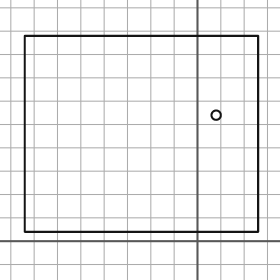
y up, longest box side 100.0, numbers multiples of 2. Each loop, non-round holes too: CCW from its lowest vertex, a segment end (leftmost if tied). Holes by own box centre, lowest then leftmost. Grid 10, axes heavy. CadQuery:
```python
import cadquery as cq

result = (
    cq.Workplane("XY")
    .moveTo(-74.0, 4.0)
    .lineTo(26.0, 4.0)
    .lineTo(26.0, 88.0)
    .lineTo(-74.0, 88.0)
    .close()
    .moveTo(8.0, 54.0)
    .circle(2.0)
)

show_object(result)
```